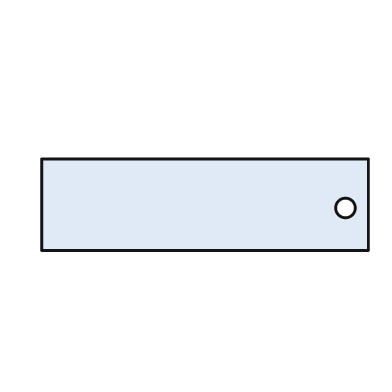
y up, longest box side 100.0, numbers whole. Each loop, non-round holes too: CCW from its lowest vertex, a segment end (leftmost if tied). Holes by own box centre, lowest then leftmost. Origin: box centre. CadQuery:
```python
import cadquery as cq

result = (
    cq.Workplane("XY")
    .moveTo(-50.0, -14.0)
    .lineTo(50.0, -14.0)
    .lineTo(50.0, 14.0)
    .lineTo(-50.0, 14.0)
    .close()
    .moveTo(43.0, -1.0)
    .circle(3.0)
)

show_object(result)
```